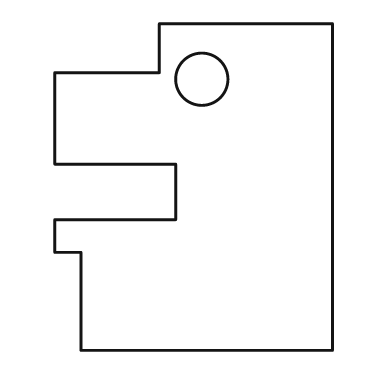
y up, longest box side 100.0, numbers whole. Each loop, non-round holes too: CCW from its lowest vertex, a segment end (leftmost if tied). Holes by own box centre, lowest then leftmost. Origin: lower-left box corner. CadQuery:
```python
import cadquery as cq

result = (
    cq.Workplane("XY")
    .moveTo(8.0, 0.0)
    .lineTo(85.0, 0.0)
    .lineTo(85.0, 100.0)
    .lineTo(32.0, 100.0)
    .lineTo(32.0, 85.0)
    .lineTo(0.0, 85.0)
    .lineTo(0.0, 57.0)
    .lineTo(37.0, 57.0)
    .lineTo(37.0, 40.0)
    .lineTo(0.0, 40.0)
    .lineTo(0.0, 30.0)
    .lineTo(8.0, 30.0)
    .close()
    .moveTo(45.0, 83.0)
    .circle(8.0)
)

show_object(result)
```